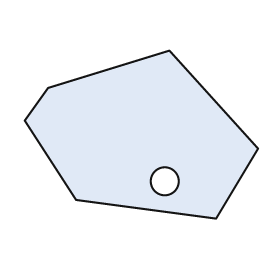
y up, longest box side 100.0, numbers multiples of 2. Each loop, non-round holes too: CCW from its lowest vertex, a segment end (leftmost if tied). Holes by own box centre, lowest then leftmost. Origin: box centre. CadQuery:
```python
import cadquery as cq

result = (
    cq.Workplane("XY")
    .moveTo(32.0, -36.0)
    .lineTo(50.0, -6.0)
    .lineTo(12.0, 36.0)
    .lineTo(-40.0, 20.0)
    .lineTo(-50.0, 6.0)
    .lineTo(-28.0, -28.0)
    .close()
    .moveTo(10.0, -20.0)
    .circle(6.0)
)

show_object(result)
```